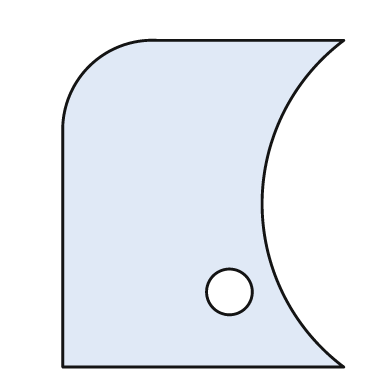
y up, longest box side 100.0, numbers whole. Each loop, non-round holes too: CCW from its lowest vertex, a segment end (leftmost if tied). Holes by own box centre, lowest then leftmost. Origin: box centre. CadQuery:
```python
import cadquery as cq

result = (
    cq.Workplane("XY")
    .moveTo(-43.0, -50.0)
    .lineTo(43.0, -50.0)
    .threePointArc((18.0, 0.0), (43.0, 50.0))
    .lineTo(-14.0, 50.0)
    .threePointArc((-35.0, 42.0), (-43.0, 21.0))
    .close()
    .moveTo(8.0, -27.0)
    .circle(7.0)
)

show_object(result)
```